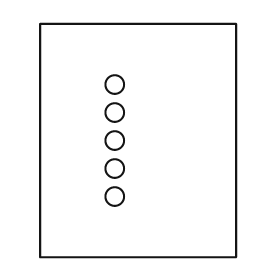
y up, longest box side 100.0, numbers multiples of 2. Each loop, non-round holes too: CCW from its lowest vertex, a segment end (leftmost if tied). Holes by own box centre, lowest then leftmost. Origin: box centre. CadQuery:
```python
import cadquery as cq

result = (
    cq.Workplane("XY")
    .moveTo(-42.0, -50.0)
    .lineTo(42.0, -50.0)
    .lineTo(42.0, 50.0)
    .lineTo(-42.0, 50.0)
    .close()
    .moveTo(-10.0, -24.0)
    .circle(4.0)
    .moveTo(-10.0, -12.0)
    .circle(4.0)
    .moveTo(-10.0, 0.0)
    .circle(4.0)
    .moveTo(-10.0, 12.0)
    .circle(4.0)
    .moveTo(-10.0, 24.0)
    .circle(4.0)
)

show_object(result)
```